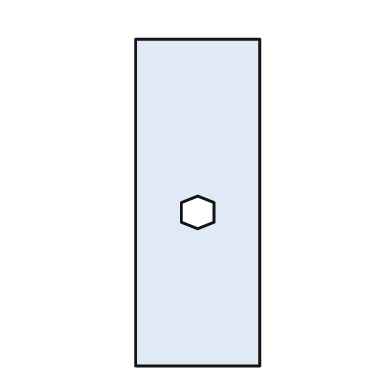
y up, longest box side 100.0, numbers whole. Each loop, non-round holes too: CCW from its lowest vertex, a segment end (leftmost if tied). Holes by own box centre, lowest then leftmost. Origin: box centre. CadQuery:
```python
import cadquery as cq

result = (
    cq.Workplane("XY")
    .moveTo(-19.0, -50.0)
    .lineTo(19.0, -50.0)
    .lineTo(19.0, 50.0)
    .lineTo(-19.0, 50.0)
    .close()
    .moveTo(0.0, -8.0)
    .lineTo(5.0, -6.0)
    .lineTo(5.0, 0.0)
    .lineTo(0.0, 2.0)
    .lineTo(-5.0, 0.0)
    .lineTo(-5.0, -6.0)
    .close()
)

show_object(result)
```